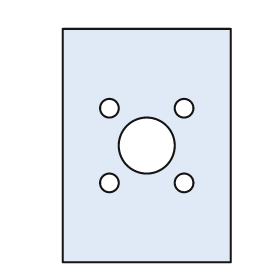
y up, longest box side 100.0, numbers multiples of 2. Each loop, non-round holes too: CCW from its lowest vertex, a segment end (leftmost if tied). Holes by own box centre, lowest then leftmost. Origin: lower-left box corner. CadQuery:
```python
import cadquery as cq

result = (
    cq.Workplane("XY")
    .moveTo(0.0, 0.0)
    .lineTo(72.0, 0.0)
    .lineTo(72.0, 100.0)
    .lineTo(0.0, 100.0)
    .close()
    .moveTo(20.0, 34.0)
    .circle(4.0)
    .moveTo(52.0, 34.0)
    .circle(4.0)
    .moveTo(36.0, 50.0)
    .circle(12.0)
    .moveTo(20.0, 66.0)
    .circle(4.0)
    .moveTo(52.0, 66.0)
    .circle(4.0)
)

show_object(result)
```